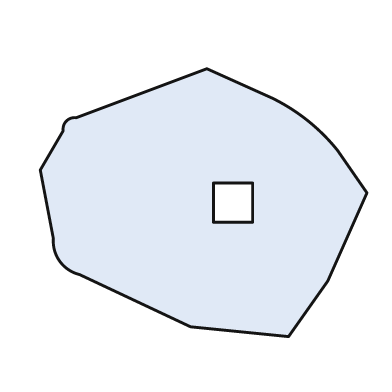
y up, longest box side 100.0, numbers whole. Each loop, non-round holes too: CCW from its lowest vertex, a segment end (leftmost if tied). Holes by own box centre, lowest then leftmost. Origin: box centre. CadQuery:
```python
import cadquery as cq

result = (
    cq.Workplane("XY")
    .moveTo(26.0, -41.0)
    .lineTo(38.0, -24.0)
    .lineTo(50.0, 3.0)
    .lineTo(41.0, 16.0)
    .threePointArc((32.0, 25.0), (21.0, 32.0))
    .lineTo(1.0, 41.0)
    .lineTo(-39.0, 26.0)
    .threePointArc((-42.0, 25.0), (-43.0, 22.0))
    .lineTo(-50.0, 10.0)
    .lineTo(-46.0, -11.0)
    .threePointArc((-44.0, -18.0), (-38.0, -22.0))
    .lineTo(-4.0, -38.0)
    .close()
    .moveTo(3.0, -6.0)
    .lineTo(15.0, -6.0)
    .lineTo(15.0, 6.0)
    .lineTo(3.0, 6.0)
    .close()
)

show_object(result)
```